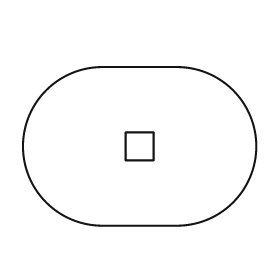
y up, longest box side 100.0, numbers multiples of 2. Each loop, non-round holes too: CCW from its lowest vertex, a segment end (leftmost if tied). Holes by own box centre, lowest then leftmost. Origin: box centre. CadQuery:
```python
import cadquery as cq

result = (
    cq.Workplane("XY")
    .moveTo(-16.0, -34.0)
    .lineTo(16.0, -34.0)
    .threePointArc((50.0, 0.0), (16.0, 34.0))
    .lineTo(-16.0, 34.0)
    .threePointArc((-50.0, 0.0), (-16.0, -34.0))
    .close()
    .moveTo(-6.0, -6.0)
    .lineTo(6.0, -6.0)
    .lineTo(6.0, 6.0)
    .lineTo(-6.0, 6.0)
    .close()
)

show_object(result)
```